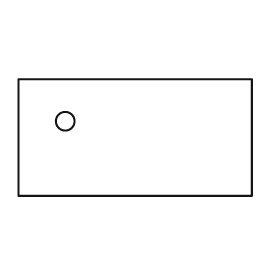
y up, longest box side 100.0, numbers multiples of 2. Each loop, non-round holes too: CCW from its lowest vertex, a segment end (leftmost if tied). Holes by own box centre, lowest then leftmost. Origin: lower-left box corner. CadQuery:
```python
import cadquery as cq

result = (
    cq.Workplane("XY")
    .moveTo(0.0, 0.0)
    .lineTo(100.0, 0.0)
    .lineTo(100.0, 50.0)
    .lineTo(0.0, 50.0)
    .close()
    .moveTo(20.0, 32.0)
    .circle(4.0)
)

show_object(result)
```